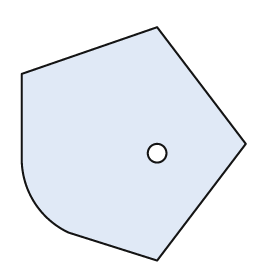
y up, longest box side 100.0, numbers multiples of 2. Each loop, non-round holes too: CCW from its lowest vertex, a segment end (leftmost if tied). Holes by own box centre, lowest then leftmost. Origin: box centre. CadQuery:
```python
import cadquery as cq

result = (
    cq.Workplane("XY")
    .moveTo(10.0, -50.0)
    .lineTo(48.0, 0.0)
    .lineTo(10.0, 50.0)
    .lineTo(-48.0, 30.0)
    .lineTo(-48.0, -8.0)
    .threePointArc((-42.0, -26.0), (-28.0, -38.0))
    .close()
    .moveTo(10.0, -4.0)
    .circle(4.0)
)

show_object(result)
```